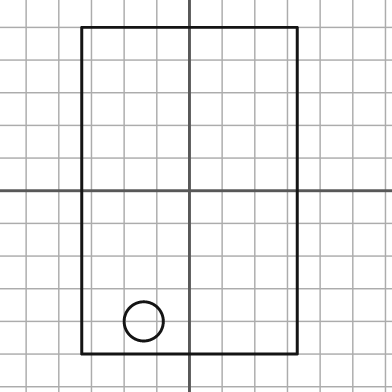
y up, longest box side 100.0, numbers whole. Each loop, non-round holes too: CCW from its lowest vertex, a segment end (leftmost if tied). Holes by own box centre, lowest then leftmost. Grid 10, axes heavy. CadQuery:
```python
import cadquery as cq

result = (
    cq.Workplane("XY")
    .moveTo(-33.0, -50.0)
    .lineTo(33.0, -50.0)
    .lineTo(33.0, 50.0)
    .lineTo(-33.0, 50.0)
    .close()
    .moveTo(-14.0, -40.0)
    .circle(6.0)
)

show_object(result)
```